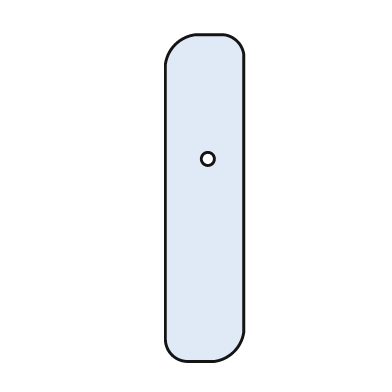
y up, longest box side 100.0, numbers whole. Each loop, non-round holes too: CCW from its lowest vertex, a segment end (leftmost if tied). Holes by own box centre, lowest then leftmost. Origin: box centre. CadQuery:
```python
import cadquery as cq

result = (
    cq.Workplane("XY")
    .moveTo(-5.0, -50.0)
    .lineTo(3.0, -50.0)
    .threePointArc((9.0, -47.0), (12.0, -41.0))
    .lineTo(12.0, 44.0)
    .threePointArc((10.0, 48.0), (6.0, 50.0))
    .lineTo(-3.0, 50.0)
    .threePointArc((-9.0, 47.0), (-12.0, 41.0))
    .lineTo(-12.0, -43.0)
    .threePointArc((-10.0, -48.0), (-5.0, -50.0))
    .close()
    .moveTo(1.0, 12.0)
    .circle(2.0)
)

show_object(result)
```